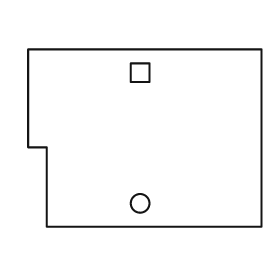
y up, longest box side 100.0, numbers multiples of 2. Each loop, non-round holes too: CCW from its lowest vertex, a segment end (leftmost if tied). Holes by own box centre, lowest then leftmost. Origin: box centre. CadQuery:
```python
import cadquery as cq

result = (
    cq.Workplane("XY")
    .moveTo(-42.0, -38.0)
    .lineTo(50.0, -38.0)
    .lineTo(50.0, 38.0)
    .lineTo(-50.0, 38.0)
    .lineTo(-50.0, -4.0)
    .lineTo(-42.0, -4.0)
    .close()
    .moveTo(-2.0, -28.0)
    .circle(4.0)
    .moveTo(-6.0, 24.0)
    .lineTo(2.0, 24.0)
    .lineTo(2.0, 32.0)
    .lineTo(-6.0, 32.0)
    .close()
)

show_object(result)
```